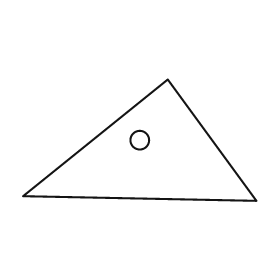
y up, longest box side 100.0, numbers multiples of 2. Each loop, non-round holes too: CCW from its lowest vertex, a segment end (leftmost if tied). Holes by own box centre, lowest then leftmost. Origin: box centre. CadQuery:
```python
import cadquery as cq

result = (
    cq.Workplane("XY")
    .moveTo(50.0, -26.0)
    .lineTo(12.0, 26.0)
    .lineTo(-50.0, -24.0)
    .close()
    .moveTo(0.0, 0.0)
    .circle(4.0)
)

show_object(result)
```